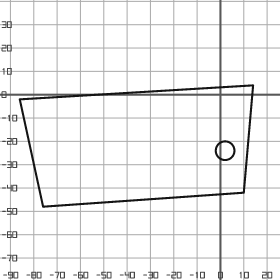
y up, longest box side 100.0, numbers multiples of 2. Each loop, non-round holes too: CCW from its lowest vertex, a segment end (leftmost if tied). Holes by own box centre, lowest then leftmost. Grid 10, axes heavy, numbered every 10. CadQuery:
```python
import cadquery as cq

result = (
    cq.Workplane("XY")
    .moveTo(-76.0, -48.0)
    .lineTo(10.0, -42.0)
    .lineTo(14.0, 4.0)
    .lineTo(-86.0, -2.0)
    .close()
    .moveTo(2.0, -24.0)
    .circle(4.0)
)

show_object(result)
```